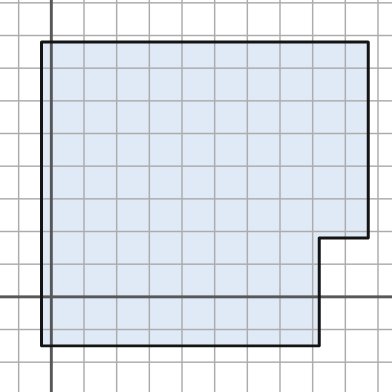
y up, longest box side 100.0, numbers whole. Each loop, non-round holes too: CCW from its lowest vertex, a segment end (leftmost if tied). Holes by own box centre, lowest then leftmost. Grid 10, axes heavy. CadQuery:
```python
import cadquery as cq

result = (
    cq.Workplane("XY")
    .moveTo(-3.0, -15.0)
    .lineTo(82.0, -15.0)
    .lineTo(82.0, 18.0)
    .lineTo(97.0, 18.0)
    .lineTo(97.0, 78.0)
    .lineTo(-3.0, 78.0)
    .close()
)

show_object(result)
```